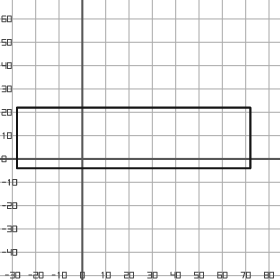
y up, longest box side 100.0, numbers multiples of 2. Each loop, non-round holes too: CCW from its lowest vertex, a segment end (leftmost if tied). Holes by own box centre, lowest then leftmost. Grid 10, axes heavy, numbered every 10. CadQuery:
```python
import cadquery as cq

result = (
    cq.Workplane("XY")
    .moveTo(-28.0, -4.0)
    .lineTo(72.0, -4.0)
    .lineTo(72.0, 22.0)
    .lineTo(-28.0, 22.0)
    .close()
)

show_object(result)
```